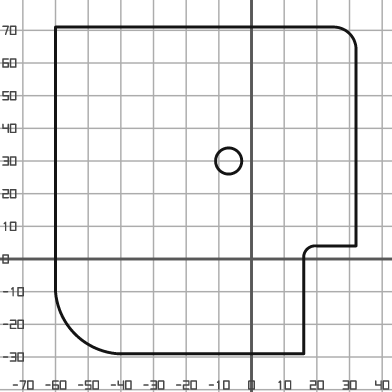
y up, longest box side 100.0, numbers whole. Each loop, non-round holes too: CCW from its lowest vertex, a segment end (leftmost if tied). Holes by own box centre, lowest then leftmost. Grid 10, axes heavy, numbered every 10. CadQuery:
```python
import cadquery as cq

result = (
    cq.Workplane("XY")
    .moveTo(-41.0, -29.0)
    .lineTo(16.0, -29.0)
    .lineTo(16.0, 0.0)
    .threePointArc((17.0, 3.0), (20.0, 4.0))
    .lineTo(32.0, 4.0)
    .lineTo(32.0, 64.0)
    .threePointArc((30.0, 69.0), (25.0, 71.0))
    .lineTo(-60.0, 71.0)
    .lineTo(-60.0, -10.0)
    .threePointArc((-54.0, -23.0), (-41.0, -29.0))
    .close()
    .moveTo(-7.0, 30.0)
    .circle(4.0)
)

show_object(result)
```